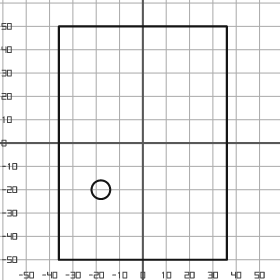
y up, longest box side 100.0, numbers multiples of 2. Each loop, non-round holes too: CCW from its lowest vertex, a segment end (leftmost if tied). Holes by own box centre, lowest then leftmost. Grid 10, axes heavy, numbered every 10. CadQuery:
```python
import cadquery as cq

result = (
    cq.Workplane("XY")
    .moveTo(-36.0, -50.0)
    .lineTo(36.0, -50.0)
    .lineTo(36.0, 50.0)
    .lineTo(-36.0, 50.0)
    .close()
    .moveTo(-18.0, -20.0)
    .circle(4.0)
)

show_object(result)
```